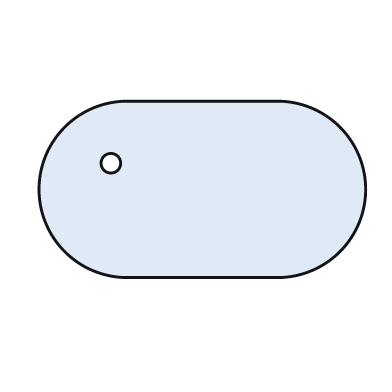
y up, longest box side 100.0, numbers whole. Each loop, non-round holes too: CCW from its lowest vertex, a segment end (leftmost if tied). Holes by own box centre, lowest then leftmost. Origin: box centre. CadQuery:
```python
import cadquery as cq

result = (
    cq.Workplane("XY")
    .moveTo(-23.0, -27.0)
    .lineTo(23.0, -27.0)
    .threePointArc((50.0, 0.0), (23.0, 27.0))
    .lineTo(-23.0, 27.0)
    .threePointArc((-50.0, 0.0), (-23.0, -27.0))
    .close()
    .moveTo(-28.0, 8.0)
    .circle(3.0)
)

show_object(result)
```